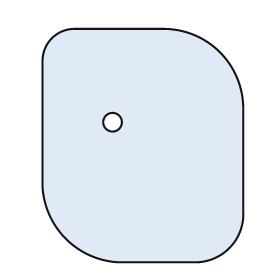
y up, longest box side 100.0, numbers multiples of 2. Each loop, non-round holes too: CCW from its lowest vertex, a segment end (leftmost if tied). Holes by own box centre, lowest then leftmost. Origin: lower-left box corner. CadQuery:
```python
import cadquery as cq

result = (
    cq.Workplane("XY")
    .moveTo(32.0, 0.0)
    .lineTo(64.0, 0.0)
    .threePointArc((80.0, 6.0), (86.0, 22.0))
    .lineTo(86.0, 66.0)
    .threePointArc((76.0, 90.0), (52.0, 100.0))
    .lineTo(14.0, 100.0)
    .threePointArc((4.0, 96.0), (0.0, 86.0))
    .lineTo(0.0, 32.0)
    .threePointArc((10.0, 10.0), (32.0, 0.0))
    .close()
    .moveTo(30.0, 60.0)
    .circle(4.0)
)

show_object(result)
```